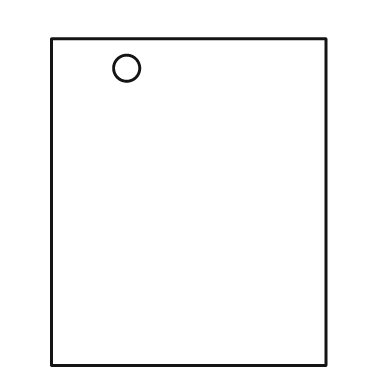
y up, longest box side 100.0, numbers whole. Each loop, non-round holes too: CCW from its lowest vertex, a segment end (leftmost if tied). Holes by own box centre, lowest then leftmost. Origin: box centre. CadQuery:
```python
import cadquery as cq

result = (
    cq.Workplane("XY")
    .moveTo(-42.0, -50.0)
    .lineTo(42.0, -50.0)
    .lineTo(42.0, 50.0)
    .lineTo(-42.0, 50.0)
    .close()
    .moveTo(-19.0, 41.0)
    .circle(4.0)
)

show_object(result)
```